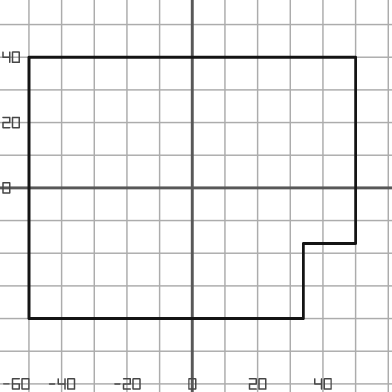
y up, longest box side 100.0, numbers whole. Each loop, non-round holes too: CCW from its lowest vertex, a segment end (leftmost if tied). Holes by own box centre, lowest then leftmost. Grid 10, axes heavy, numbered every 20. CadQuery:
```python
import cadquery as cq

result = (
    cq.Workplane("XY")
    .moveTo(-50.0, -40.0)
    .lineTo(34.0, -40.0)
    .lineTo(34.0, -17.0)
    .lineTo(50.0, -17.0)
    .lineTo(50.0, 40.0)
    .lineTo(-50.0, 40.0)
    .close()
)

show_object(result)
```